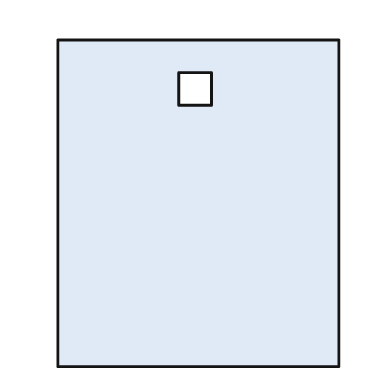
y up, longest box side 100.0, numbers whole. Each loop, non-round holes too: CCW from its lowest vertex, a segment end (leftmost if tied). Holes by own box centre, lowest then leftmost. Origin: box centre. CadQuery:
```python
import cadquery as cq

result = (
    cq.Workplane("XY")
    .moveTo(-43.0, -50.0)
    .lineTo(43.0, -50.0)
    .lineTo(43.0, 50.0)
    .lineTo(-43.0, 50.0)
    .close()
    .moveTo(-6.0, 30.0)
    .lineTo(4.0, 30.0)
    .lineTo(4.0, 40.0)
    .lineTo(-6.0, 40.0)
    .close()
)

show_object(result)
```